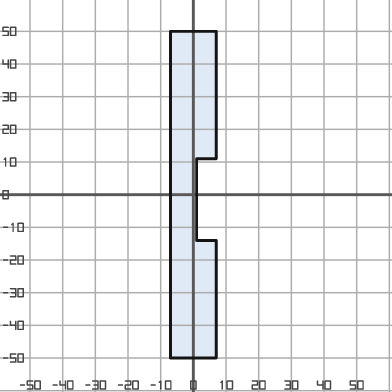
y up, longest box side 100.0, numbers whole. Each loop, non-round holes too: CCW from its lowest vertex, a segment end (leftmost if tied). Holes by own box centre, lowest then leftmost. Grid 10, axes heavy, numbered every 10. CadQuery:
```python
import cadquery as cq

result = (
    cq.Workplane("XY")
    .moveTo(-7.0, -50.0)
    .lineTo(7.0, -50.0)
    .lineTo(7.0, -14.0)
    .lineTo(1.0, -14.0)
    .lineTo(1.0, 11.0)
    .lineTo(7.0, 11.0)
    .lineTo(7.0, 50.0)
    .lineTo(-7.0, 50.0)
    .close()
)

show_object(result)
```